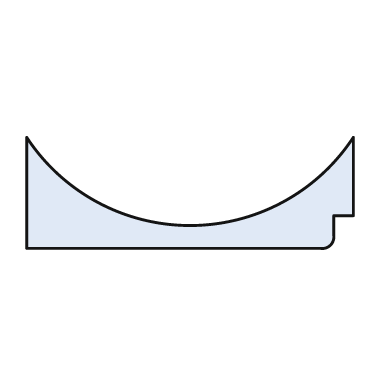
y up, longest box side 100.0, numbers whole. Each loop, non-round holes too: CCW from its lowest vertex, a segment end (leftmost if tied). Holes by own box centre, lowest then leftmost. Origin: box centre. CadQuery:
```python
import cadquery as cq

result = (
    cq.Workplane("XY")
    .moveTo(-50.0, -17.0)
    .lineTo(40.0, -17.0)
    .threePointArc((43.0, -16.0), (44.0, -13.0))
    .lineTo(44.0, -7.0)
    .lineTo(50.0, -7.0)
    .lineTo(50.0, 17.0)
    .threePointArc((0.0, -10.0), (-50.0, 17.0))
    .close()
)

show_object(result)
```